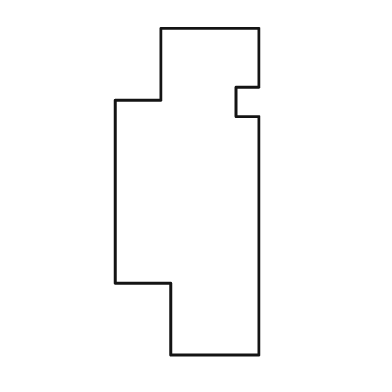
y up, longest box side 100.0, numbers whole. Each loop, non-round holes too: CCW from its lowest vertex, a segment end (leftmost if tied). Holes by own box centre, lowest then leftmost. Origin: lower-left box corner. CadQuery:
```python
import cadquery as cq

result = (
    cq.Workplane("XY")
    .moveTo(17.0, 0.0)
    .lineTo(44.0, 0.0)
    .lineTo(44.0, 73.0)
    .lineTo(37.0, 73.0)
    .lineTo(37.0, 82.0)
    .lineTo(44.0, 82.0)
    .lineTo(44.0, 100.0)
    .lineTo(14.0, 100.0)
    .lineTo(14.0, 78.0)
    .lineTo(0.0, 78.0)
    .lineTo(0.0, 22.0)
    .lineTo(17.0, 22.0)
    .close()
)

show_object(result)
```